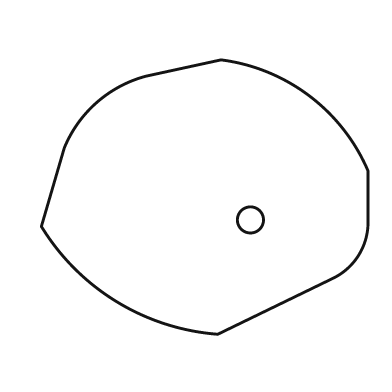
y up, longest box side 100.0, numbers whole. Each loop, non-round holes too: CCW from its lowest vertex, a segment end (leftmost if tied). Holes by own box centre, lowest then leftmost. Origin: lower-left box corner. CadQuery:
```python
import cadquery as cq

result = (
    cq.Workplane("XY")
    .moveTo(54.0, 0.0)
    .lineTo(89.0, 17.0)
    .threePointArc((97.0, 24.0), (100.0, 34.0))
    .lineTo(100.0, 50.0)
    .threePointArc((82.0, 73.0), (55.0, 84.0))
    .lineTo(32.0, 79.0)
    .threePointArc((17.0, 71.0), (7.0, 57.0))
    .lineTo(0.0, 33.0)
    .threePointArc((23.0, 10.0), (54.0, 0.0))
    .close()
    .moveTo(64.0, 35.0)
    .circle(4.0)
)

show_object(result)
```